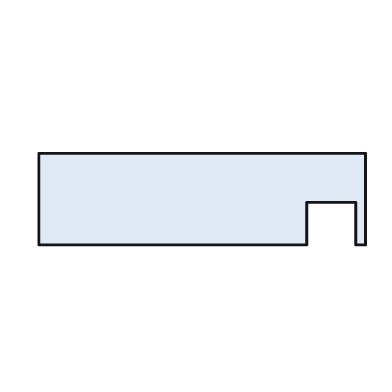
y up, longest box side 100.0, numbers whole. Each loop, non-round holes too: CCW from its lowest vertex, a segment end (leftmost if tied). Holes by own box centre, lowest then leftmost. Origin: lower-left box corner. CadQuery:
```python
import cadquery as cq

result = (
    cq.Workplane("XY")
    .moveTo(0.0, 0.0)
    .lineTo(82.0, 0.0)
    .lineTo(82.0, 13.0)
    .lineTo(97.0, 13.0)
    .lineTo(97.0, 0.0)
    .lineTo(100.0, 0.0)
    .lineTo(100.0, 28.0)
    .lineTo(0.0, 28.0)
    .close()
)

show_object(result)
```